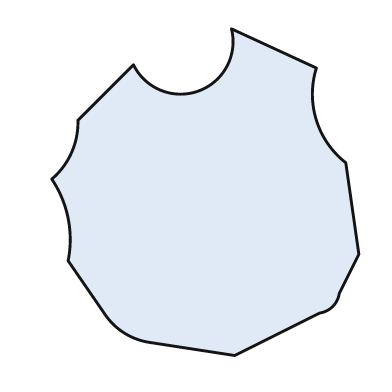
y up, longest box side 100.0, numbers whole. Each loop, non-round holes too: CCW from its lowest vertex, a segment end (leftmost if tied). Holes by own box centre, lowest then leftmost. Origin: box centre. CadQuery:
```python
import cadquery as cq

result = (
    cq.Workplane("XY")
    .moveTo(9.0, -50.0)
    .lineTo(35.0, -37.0)
    .threePointArc((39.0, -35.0), (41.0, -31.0))
    .lineTo(47.0, -19.0)
    .lineTo(43.0, 9.0)
    .threePointArc((34.0, 22.0), (34.0, 38.0))
    .lineTo(8.0, 50.0)
    .threePointArc((-2.0, 31.0), (-22.0, 39.0))
    .lineTo(-39.0, 22.0)
    .threePointArc((-41.0, 12.0), (-47.0, 4.0))
    .threePointArc((-42.0, -8.0), (-42.0, -21.0))
    .lineTo(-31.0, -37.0)
    .threePointArc((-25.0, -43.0), (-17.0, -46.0))
    .close()
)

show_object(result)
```